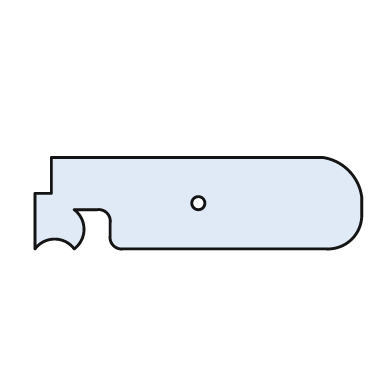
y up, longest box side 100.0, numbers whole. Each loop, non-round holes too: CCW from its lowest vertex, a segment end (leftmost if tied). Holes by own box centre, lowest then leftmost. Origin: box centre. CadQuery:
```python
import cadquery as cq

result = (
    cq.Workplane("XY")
    .moveTo(-50.0, -14.0)
    .threePointArc((-44.0, -11.0), (-38.0, -14.0))
    .threePointArc((-35.0, -8.0), (-38.0, -2.0))
    .lineTo(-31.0, -2.0)
    .threePointArc((-28.0, -3.0), (-27.0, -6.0))
    .lineTo(-27.0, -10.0)
    .threePointArc((-26.0, -13.0), (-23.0, -14.0))
    .lineTo(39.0, -14.0)
    .threePointArc((47.0, -11.0), (50.0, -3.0))
    .lineTo(50.0, 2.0)
    .threePointArc((46.0, 10.0), (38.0, 14.0))
    .lineTo(-45.0, 14.0)
    .lineTo(-45.0, 3.0)
    .lineTo(-50.0, 3.0)
    .close()
    .moveTo(0.0, 0.0)
    .circle(2.0)
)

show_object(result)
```